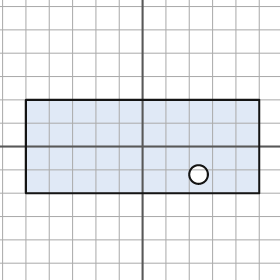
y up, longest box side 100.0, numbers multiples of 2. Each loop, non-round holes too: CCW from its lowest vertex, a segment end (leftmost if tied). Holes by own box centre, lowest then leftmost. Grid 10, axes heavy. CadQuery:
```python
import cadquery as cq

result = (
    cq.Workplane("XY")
    .moveTo(-50.0, -20.0)
    .lineTo(50.0, -20.0)
    .lineTo(50.0, 20.0)
    .lineTo(-50.0, 20.0)
    .close()
    .moveTo(24.0, -12.0)
    .circle(4.0)
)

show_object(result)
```